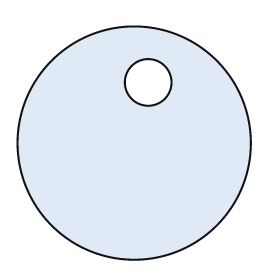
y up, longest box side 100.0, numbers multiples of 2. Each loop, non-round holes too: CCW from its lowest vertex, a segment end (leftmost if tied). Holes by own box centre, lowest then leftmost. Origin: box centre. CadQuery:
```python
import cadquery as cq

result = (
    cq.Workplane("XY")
    .moveTo(0.0, 0.0)
    .circle(50.0)
    .moveTo(6.0, 26.0)
    .circle(10.0)
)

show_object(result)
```